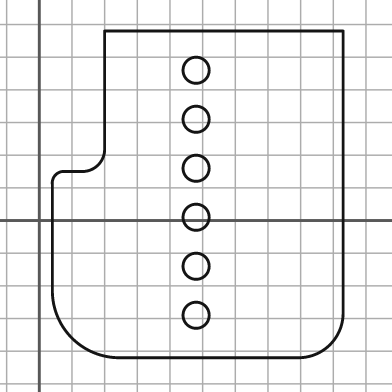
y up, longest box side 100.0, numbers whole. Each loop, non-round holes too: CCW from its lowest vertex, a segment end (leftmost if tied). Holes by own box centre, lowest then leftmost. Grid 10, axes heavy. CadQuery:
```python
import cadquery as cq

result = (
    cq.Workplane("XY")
    .moveTo(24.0, -42.0)
    .lineTo(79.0, -42.0)
    .threePointArc((89.0, -38.0), (93.0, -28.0))
    .lineTo(93.0, 58.0)
    .lineTo(20.0, 58.0)
    .lineTo(20.0, 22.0)
    .threePointArc((18.0, 17.0), (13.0, 15.0))
    .lineTo(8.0, 15.0)
    .threePointArc((5.0, 14.0), (4.0, 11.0))
    .lineTo(4.0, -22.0)
    .threePointArc((10.0, -36.0), (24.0, -42.0))
    .close()
    .moveTo(48.0, -29.0)
    .circle(4.0)
    .moveTo(48.0, -14.0)
    .circle(4.0)
    .moveTo(48.0, 1.0)
    .circle(4.0)
    .moveTo(48.0, 16.0)
    .circle(4.0)
    .moveTo(48.0, 31.0)
    .circle(4.0)
    .moveTo(48.0, 46.0)
    .circle(4.0)
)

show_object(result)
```